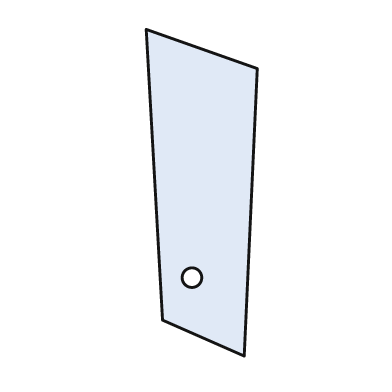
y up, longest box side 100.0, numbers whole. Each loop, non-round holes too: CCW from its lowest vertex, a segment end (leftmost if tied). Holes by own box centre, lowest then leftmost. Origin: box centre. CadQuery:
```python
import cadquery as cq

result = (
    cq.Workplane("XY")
    .moveTo(13.0, -50.0)
    .lineTo(17.0, 38.0)
    .lineTo(-17.0, 50.0)
    .lineTo(-12.0, -39.0)
    .close()
    .moveTo(-3.0, -26.0)
    .circle(3.0)
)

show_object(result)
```